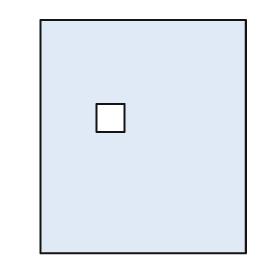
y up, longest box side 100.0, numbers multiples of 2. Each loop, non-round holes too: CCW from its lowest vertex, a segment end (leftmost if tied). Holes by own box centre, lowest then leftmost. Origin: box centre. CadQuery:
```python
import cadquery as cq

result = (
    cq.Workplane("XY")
    .moveTo(-44.0, -50.0)
    .lineTo(44.0, -50.0)
    .lineTo(44.0, 50.0)
    .lineTo(-44.0, 50.0)
    .close()
    .moveTo(-20.0, 2.0)
    .lineTo(-8.0, 2.0)
    .lineTo(-8.0, 14.0)
    .lineTo(-20.0, 14.0)
    .close()
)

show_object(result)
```